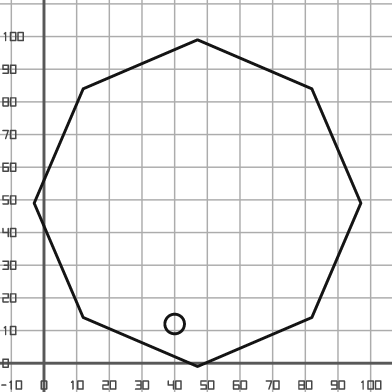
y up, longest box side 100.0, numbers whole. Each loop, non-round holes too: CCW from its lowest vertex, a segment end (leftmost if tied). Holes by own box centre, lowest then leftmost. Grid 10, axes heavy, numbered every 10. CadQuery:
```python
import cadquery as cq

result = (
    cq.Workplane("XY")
    .moveTo(47.0, -1.0)
    .lineTo(82.0, 14.0)
    .lineTo(97.0, 49.0)
    .lineTo(82.0, 84.0)
    .lineTo(47.0, 99.0)
    .lineTo(12.0, 84.0)
    .lineTo(-3.0, 49.0)
    .lineTo(12.0, 14.0)
    .close()
    .moveTo(40.0, 12.0)
    .circle(3.0)
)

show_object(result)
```